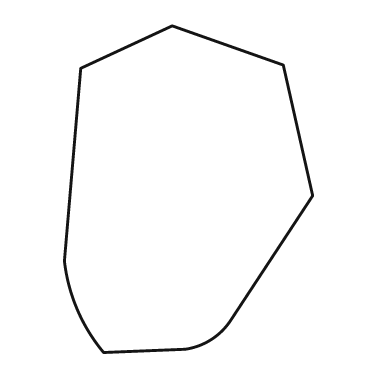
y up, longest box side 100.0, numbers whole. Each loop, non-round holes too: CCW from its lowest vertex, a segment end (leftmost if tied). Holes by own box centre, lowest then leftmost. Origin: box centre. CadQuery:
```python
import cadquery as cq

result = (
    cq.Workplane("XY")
    .moveTo(-26.0, -50.0)
    .lineTo(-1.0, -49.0)
    .threePointArc((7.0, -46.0), (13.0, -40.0))
    .lineTo(38.0, -2.0)
    .lineTo(29.0, 38.0)
    .lineTo(-5.0, 50.0)
    .lineTo(-33.0, 37.0)
    .lineTo(-38.0, -22.0)
    .threePointArc((-34.0, -37.0), (-26.0, -50.0))
    .close()
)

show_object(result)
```